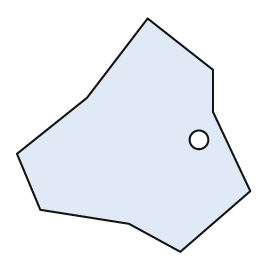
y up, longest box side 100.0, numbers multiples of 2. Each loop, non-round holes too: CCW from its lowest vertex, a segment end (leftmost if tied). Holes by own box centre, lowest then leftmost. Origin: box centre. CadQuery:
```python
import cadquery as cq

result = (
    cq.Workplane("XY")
    .moveTo(20.0, -50.0)
    .lineTo(50.0, -24.0)
    .lineTo(34.0, 10.0)
    .lineTo(34.0, 28.0)
    .lineTo(6.0, 50.0)
    .lineTo(-20.0, 16.0)
    .lineTo(-50.0, -8.0)
    .lineTo(-40.0, -32.0)
    .lineTo(-2.0, -38.0)
    .close()
    .moveTo(28.0, -2.0)
    .circle(4.0)
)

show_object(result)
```